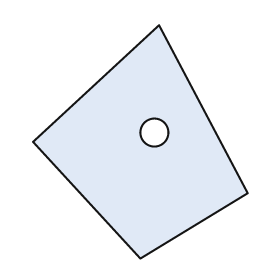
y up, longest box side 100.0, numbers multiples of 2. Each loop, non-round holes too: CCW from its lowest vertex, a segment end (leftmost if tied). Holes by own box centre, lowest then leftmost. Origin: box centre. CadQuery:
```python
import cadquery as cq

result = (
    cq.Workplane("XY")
    .moveTo(0.0, -50.0)
    .lineTo(46.0, -22.0)
    .lineTo(8.0, 50.0)
    .lineTo(-46.0, 0.0)
    .close()
    .moveTo(6.0, 4.0)
    .circle(6.0)
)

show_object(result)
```